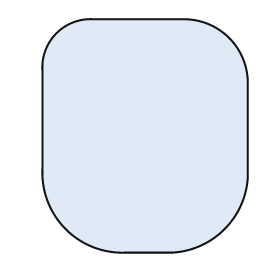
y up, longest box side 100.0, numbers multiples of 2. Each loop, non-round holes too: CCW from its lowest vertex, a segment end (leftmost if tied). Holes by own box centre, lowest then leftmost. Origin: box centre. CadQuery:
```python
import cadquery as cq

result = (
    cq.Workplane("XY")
    .moveTo(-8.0, -50.0)
    .lineTo(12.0, -50.0)
    .threePointArc((34.0, -40.0), (44.0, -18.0))
    .lineTo(44.0, 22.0)
    .threePointArc((36.0, 42.0), (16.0, 50.0))
    .lineTo(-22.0, 50.0)
    .threePointArc((-38.0, 44.0), (-44.0, 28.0))
    .lineTo(-44.0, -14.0)
    .threePointArc((-34.0, -40.0), (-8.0, -50.0))
    .close()
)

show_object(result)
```